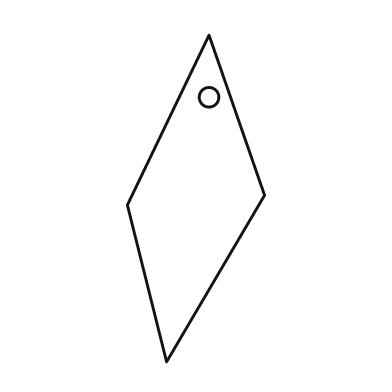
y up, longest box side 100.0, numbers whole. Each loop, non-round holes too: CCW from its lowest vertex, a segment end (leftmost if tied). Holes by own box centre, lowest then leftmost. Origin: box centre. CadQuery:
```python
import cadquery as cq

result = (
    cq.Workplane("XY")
    .moveTo(-9.0, -50.0)
    .lineTo(21.0, 1.0)
    .lineTo(4.0, 50.0)
    .lineTo(-21.0, -2.0)
    .close()
    .moveTo(4.0, 31.0)
    .circle(3.0)
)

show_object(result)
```